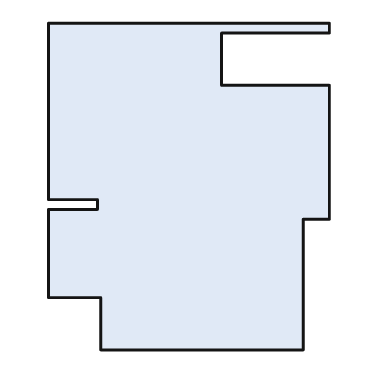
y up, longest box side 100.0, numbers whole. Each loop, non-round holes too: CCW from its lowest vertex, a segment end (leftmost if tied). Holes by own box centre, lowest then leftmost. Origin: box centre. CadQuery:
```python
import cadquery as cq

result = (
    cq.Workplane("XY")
    .moveTo(-27.0, -50.0)
    .lineTo(35.0, -50.0)
    .lineTo(35.0, -10.0)
    .lineTo(43.0, -10.0)
    .lineTo(43.0, 31.0)
    .lineTo(10.0, 31.0)
    .lineTo(10.0, 47.0)
    .lineTo(43.0, 47.0)
    .lineTo(43.0, 50.0)
    .lineTo(-43.0, 50.0)
    .lineTo(-43.0, -4.0)
    .lineTo(-28.0, -4.0)
    .lineTo(-28.0, -7.0)
    .lineTo(-43.0, -7.0)
    .lineTo(-43.0, -34.0)
    .lineTo(-27.0, -34.0)
    .close()
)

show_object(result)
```